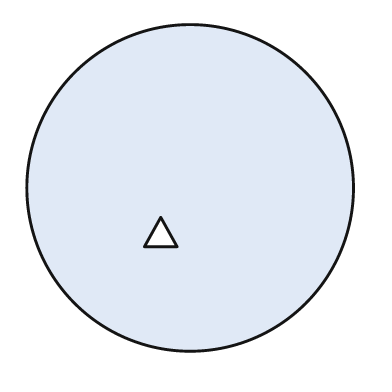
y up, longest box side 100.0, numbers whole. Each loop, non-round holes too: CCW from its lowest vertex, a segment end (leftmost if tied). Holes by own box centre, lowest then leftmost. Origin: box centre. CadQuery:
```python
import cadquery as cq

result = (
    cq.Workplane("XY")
    .moveTo(0.0, 0.0)
    .circle(50.0)
    .moveTo(-14.0, -18.0)
    .lineTo(-4.0, -18.0)
    .lineTo(-9.0, -9.0)
    .close()
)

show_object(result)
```